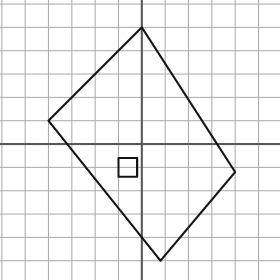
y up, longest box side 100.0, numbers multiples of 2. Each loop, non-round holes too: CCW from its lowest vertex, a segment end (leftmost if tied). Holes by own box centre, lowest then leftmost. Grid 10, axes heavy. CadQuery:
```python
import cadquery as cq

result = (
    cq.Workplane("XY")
    .moveTo(8.0, -50.0)
    .lineTo(40.0, -12.0)
    .lineTo(0.0, 50.0)
    .lineTo(-40.0, 10.0)
    .close()
    .moveTo(-10.0, -14.0)
    .lineTo(-2.0, -14.0)
    .lineTo(-2.0, -6.0)
    .lineTo(-10.0, -6.0)
    .close()
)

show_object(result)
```